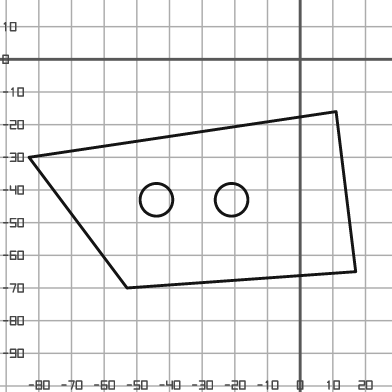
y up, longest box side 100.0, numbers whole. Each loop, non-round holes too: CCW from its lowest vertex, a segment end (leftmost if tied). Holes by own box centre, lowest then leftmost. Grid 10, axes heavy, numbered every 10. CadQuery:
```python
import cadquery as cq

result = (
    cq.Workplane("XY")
    .moveTo(-53.0, -70.0)
    .lineTo(17.0, -65.0)
    .lineTo(11.0, -16.0)
    .lineTo(-83.0, -30.0)
    .close()
    .moveTo(-44.0, -43.0)
    .circle(5.0)
    .moveTo(-21.0, -43.0)
    .circle(5.0)
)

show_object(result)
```